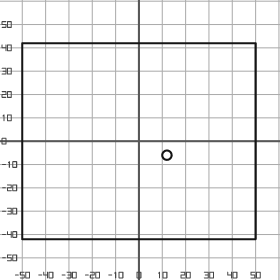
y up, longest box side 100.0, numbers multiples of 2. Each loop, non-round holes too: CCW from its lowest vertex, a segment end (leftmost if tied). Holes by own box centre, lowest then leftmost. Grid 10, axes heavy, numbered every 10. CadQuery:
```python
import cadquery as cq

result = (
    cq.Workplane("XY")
    .moveTo(-50.0, -42.0)
    .lineTo(50.0, -42.0)
    .lineTo(50.0, 42.0)
    .lineTo(-50.0, 42.0)
    .close()
    .moveTo(12.0, -6.0)
    .circle(2.0)
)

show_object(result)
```